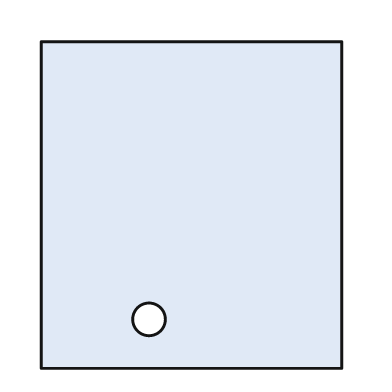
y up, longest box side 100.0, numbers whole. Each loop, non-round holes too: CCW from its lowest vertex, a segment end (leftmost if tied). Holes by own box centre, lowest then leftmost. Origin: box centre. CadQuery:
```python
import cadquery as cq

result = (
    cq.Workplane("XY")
    .moveTo(-46.0, -50.0)
    .lineTo(46.0, -50.0)
    .lineTo(46.0, 50.0)
    .lineTo(-46.0, 50.0)
    .close()
    .moveTo(-13.0, -35.0)
    .circle(5.0)
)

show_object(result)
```